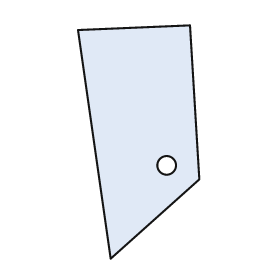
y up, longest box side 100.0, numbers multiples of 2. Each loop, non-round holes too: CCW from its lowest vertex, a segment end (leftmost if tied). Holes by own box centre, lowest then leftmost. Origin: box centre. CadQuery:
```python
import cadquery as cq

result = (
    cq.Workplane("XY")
    .moveTo(-12.0, -50.0)
    .lineTo(26.0, -16.0)
    .lineTo(22.0, 50.0)
    .lineTo(-26.0, 48.0)
    .close()
    .moveTo(12.0, -10.0)
    .circle(4.0)
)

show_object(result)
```